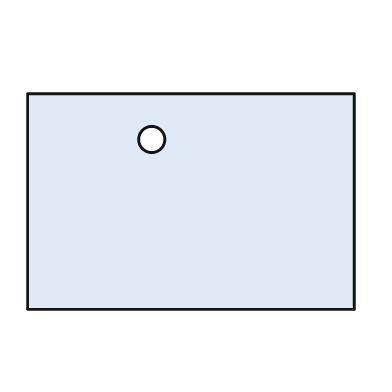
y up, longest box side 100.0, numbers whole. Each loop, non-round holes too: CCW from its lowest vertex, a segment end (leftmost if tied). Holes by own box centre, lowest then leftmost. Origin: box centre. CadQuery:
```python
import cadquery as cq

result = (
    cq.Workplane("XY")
    .moveTo(-50.0, -33.0)
    .lineTo(50.0, -33.0)
    .lineTo(50.0, 33.0)
    .lineTo(-50.0, 33.0)
    .close()
    .moveTo(-12.0, 19.0)
    .circle(4.0)
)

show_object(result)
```